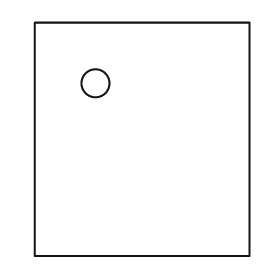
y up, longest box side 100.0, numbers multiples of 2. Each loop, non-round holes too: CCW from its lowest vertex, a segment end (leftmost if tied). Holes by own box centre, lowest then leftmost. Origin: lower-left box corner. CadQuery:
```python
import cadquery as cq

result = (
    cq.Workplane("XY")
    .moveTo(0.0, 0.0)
    .lineTo(92.0, 0.0)
    .lineTo(92.0, 100.0)
    .lineTo(0.0, 100.0)
    .close()
    .moveTo(26.0, 74.0)
    .circle(6.0)
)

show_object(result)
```